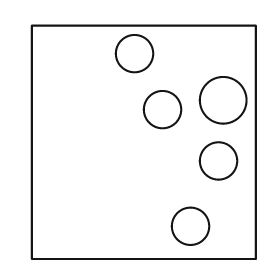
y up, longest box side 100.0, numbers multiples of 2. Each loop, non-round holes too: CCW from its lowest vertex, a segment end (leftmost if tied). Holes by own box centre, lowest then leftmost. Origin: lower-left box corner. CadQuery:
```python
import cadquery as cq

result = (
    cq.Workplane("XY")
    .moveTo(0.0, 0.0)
    .lineTo(96.0, 0.0)
    .lineTo(96.0, 100.0)
    .lineTo(0.0, 100.0)
    .close()
    .moveTo(68.0, 14.0)
    .circle(8.0)
    .moveTo(80.0, 42.0)
    .circle(8.0)
    .moveTo(56.0, 64.0)
    .circle(8.0)
    .moveTo(82.0, 68.0)
    .circle(10.0)
    .moveTo(44.0, 88.0)
    .circle(8.0)
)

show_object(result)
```